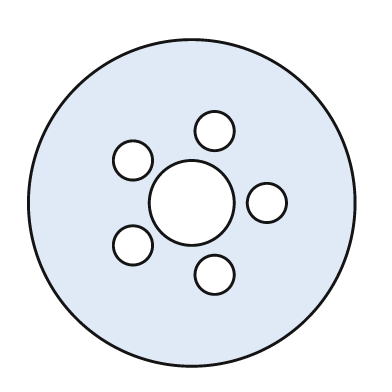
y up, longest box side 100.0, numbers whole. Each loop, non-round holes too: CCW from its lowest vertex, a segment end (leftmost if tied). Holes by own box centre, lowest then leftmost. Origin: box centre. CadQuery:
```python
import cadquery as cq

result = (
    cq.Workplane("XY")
    .moveTo(0.0, 0.0)
    .circle(50.0)
    .moveTo(7.0, -22.0)
    .circle(6.0)
    .moveTo(-18.0, -13.0)
    .circle(6.0)
    .moveTo(0.0, 0.0)
    .circle(13.0)
    .moveTo(23.0, 0.0)
    .circle(6.0)
    .moveTo(-18.0, 13.0)
    .circle(6.0)
    .moveTo(7.0, 22.0)
    .circle(6.0)
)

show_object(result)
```